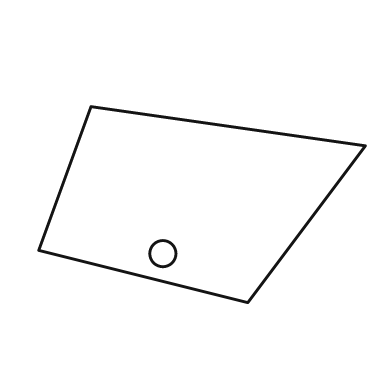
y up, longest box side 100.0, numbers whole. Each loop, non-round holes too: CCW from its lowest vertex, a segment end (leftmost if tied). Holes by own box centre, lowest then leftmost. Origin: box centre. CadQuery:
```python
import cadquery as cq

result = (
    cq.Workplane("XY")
    .moveTo(14.0, -30.0)
    .lineTo(50.0, 18.0)
    .lineTo(-34.0, 30.0)
    .lineTo(-50.0, -14.0)
    .close()
    .moveTo(-12.0, -15.0)
    .circle(4.0)
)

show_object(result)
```